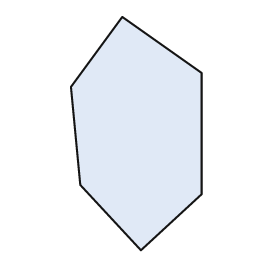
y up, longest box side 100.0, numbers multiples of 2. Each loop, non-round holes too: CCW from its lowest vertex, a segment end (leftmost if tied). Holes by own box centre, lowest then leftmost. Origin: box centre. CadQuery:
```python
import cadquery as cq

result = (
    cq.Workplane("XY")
    .moveTo(2.0, -50.0)
    .lineTo(28.0, -26.0)
    .lineTo(28.0, 26.0)
    .lineTo(-6.0, 50.0)
    .lineTo(-28.0, 20.0)
    .lineTo(-24.0, -22.0)
    .close()
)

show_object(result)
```